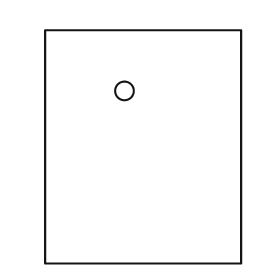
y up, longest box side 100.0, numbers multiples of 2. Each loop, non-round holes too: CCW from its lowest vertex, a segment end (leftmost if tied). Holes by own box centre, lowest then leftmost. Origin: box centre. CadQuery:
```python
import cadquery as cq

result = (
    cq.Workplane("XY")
    .moveTo(-42.0, -50.0)
    .lineTo(42.0, -50.0)
    .lineTo(42.0, 50.0)
    .lineTo(-42.0, 50.0)
    .close()
    .moveTo(-8.0, 24.0)
    .circle(4.0)
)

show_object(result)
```